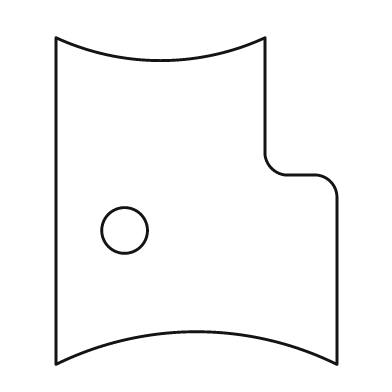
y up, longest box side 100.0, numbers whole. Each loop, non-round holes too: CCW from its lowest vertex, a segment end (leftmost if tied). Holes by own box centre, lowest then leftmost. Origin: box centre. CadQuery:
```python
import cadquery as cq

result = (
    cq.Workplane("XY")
    .moveTo(-43.0, -50.0)
    .threePointArc((0.0, -40.0), (43.0, -50.0))
    .lineTo(43.0, 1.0)
    .threePointArc((41.0, 6.0), (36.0, 8.0))
    .lineTo(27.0, 8.0)
    .threePointArc((23.0, 10.0), (21.0, 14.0))
    .lineTo(21.0, 50.0)
    .threePointArc((-11.0, 43.0), (-43.0, 50.0))
    .close()
    .moveTo(-22.0, -9.0)
    .circle(7.0)
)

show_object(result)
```